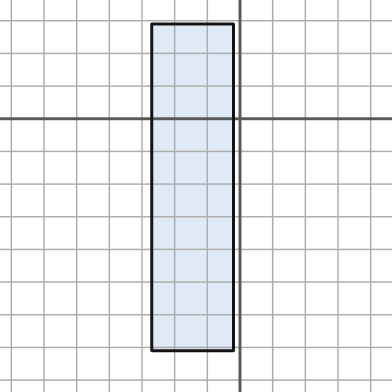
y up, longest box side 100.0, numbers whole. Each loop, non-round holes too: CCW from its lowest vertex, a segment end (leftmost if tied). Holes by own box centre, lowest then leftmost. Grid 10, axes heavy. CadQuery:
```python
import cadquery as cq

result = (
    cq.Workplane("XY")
    .moveTo(-27.0, -71.0)
    .lineTo(-2.0, -71.0)
    .lineTo(-2.0, 29.0)
    .lineTo(-27.0, 29.0)
    .close()
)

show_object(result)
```